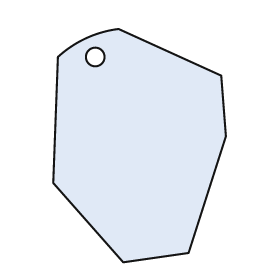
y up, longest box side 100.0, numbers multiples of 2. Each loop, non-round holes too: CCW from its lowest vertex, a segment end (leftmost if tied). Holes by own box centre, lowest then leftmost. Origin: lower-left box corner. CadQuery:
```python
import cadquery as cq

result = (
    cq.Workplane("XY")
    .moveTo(30.0, 0.0)
    .lineTo(58.0, 4.0)
    .lineTo(74.0, 54.0)
    .lineTo(72.0, 80.0)
    .lineTo(28.0, 100.0)
    .threePointArc((14.0, 96.0), (2.0, 88.0))
    .lineTo(0.0, 34.0)
    .close()
    .moveTo(18.0, 88.0)
    .circle(4.0)
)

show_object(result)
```